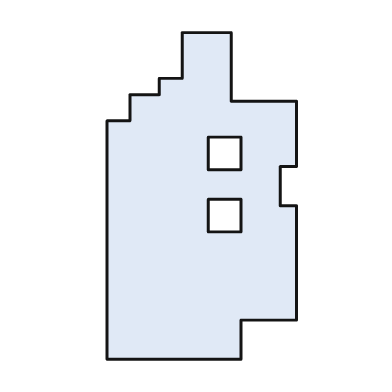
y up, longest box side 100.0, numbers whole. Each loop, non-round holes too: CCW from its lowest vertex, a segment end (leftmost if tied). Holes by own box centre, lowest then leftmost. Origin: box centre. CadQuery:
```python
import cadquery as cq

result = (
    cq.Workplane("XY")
    .moveTo(-29.0, -50.0)
    .lineTo(12.0, -50.0)
    .lineTo(12.0, -38.0)
    .lineTo(29.0, -38.0)
    .lineTo(29.0, -3.0)
    .lineTo(24.0, -3.0)
    .lineTo(24.0, 9.0)
    .lineTo(29.0, 9.0)
    .lineTo(29.0, 29.0)
    .lineTo(9.0, 29.0)
    .lineTo(9.0, 50.0)
    .lineTo(-6.0, 50.0)
    .lineTo(-6.0, 36.0)
    .lineTo(-13.0, 36.0)
    .lineTo(-13.0, 31.0)
    .lineTo(-22.0, 31.0)
    .lineTo(-22.0, 23.0)
    .lineTo(-29.0, 23.0)
    .close()
    .moveTo(2.0, -11.0)
    .lineTo(12.0, -11.0)
    .lineTo(12.0, -1.0)
    .lineTo(2.0, -1.0)
    .close()
    .moveTo(2.0, 8.0)
    .lineTo(12.0, 8.0)
    .lineTo(12.0, 18.0)
    .lineTo(2.0, 18.0)
    .close()
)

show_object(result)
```